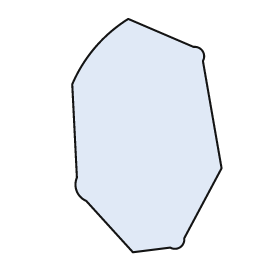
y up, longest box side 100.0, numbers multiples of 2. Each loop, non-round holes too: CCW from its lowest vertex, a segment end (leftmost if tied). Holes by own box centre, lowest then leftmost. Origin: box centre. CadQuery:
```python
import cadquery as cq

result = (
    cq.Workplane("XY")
    .moveTo(-6.0, -50.0)
    .lineTo(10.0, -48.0)
    .threePointArc((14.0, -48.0), (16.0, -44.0))
    .lineTo(32.0, -14.0)
    .lineTo(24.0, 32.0)
    .threePointArc((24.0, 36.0), (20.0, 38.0))
    .lineTo(-8.0, 50.0)
    .threePointArc((-22.0, 38.0), (-32.0, 22.0))
    .lineTo(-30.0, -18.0)
    .threePointArc((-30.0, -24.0), (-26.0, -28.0))
    .close()
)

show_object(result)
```